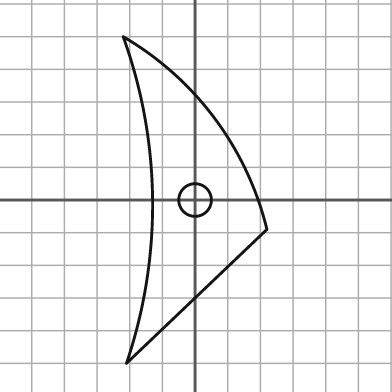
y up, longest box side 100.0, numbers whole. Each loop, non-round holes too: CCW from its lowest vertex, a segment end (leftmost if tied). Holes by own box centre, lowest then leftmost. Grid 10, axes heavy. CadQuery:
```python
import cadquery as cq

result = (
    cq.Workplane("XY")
    .moveTo(-21.0, -50.0)
    .lineTo(22.0, -9.0)
    .threePointArc((6.0, 25.0), (-22.0, 50.0))
    .threePointArc((-13.0, 0.0), (-21.0, -50.0))
    .close()
    .moveTo(0.0, 0.0)
    .circle(5.0)
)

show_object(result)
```